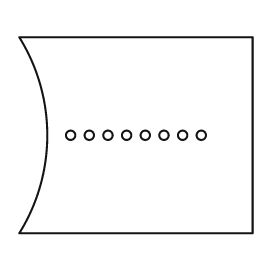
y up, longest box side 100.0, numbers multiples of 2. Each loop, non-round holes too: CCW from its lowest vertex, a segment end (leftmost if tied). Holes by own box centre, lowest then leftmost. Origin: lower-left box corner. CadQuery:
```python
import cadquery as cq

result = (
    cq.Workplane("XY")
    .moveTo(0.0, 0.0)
    .lineTo(100.0, 0.0)
    .lineTo(100.0, 84.0)
    .lineTo(0.0, 84.0)
    .threePointArc((12.0, 42.0), (0.0, 0.0))
    .close()
    .moveTo(22.0, 42.0)
    .circle(2.0)
    .moveTo(30.0, 42.0)
    .circle(2.0)
    .moveTo(38.0, 42.0)
    .circle(2.0)
    .moveTo(46.0, 42.0)
    .circle(2.0)
    .moveTo(54.0, 42.0)
    .circle(2.0)
    .moveTo(62.0, 42.0)
    .circle(2.0)
    .moveTo(70.0, 42.0)
    .circle(2.0)
    .moveTo(78.0, 42.0)
    .circle(2.0)
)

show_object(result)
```